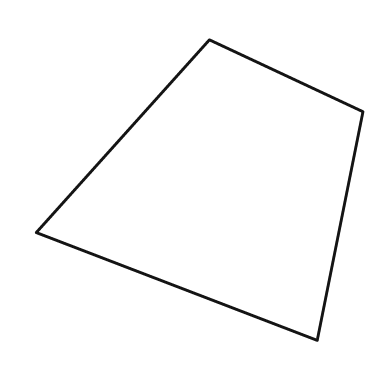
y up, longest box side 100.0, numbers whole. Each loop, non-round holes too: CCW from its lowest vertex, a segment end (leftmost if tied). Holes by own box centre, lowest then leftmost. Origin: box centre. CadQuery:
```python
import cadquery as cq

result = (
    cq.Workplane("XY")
    .moveTo(36.0, -46.0)
    .lineTo(50.0, 24.0)
    .lineTo(3.0, 46.0)
    .lineTo(-50.0, -13.0)
    .close()
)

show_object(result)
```